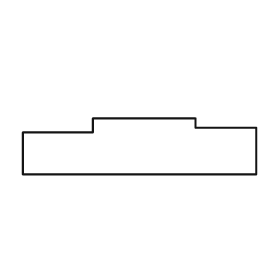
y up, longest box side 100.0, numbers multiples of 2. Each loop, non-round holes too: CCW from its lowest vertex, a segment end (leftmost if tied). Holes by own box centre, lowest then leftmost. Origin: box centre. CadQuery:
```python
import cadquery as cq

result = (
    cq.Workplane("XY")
    .moveTo(-50.0, -12.0)
    .lineTo(50.0, -12.0)
    .lineTo(50.0, 8.0)
    .lineTo(24.0, 8.0)
    .lineTo(24.0, 12.0)
    .lineTo(-20.0, 12.0)
    .lineTo(-20.0, 6.0)
    .lineTo(-50.0, 6.0)
    .close()
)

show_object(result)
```